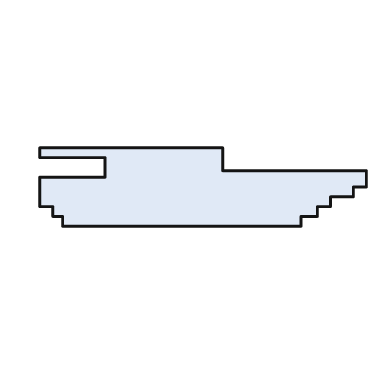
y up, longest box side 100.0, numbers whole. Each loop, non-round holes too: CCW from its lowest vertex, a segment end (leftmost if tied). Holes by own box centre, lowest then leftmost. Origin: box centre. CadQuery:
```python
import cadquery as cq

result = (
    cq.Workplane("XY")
    .moveTo(-43.0, -12.0)
    .lineTo(30.0, -12.0)
    .lineTo(30.0, -9.0)
    .lineTo(35.0, -9.0)
    .lineTo(35.0, -6.0)
    .lineTo(39.0, -6.0)
    .lineTo(39.0, -3.0)
    .lineTo(46.0, -3.0)
    .lineTo(46.0, 0.0)
    .lineTo(50.0, 0.0)
    .lineTo(50.0, 5.0)
    .lineTo(6.0, 5.0)
    .lineTo(6.0, 12.0)
    .lineTo(-50.0, 12.0)
    .lineTo(-50.0, 9.0)
    .lineTo(-30.0, 9.0)
    .lineTo(-30.0, 3.0)
    .lineTo(-50.0, 3.0)
    .lineTo(-50.0, -6.0)
    .lineTo(-46.0, -6.0)
    .lineTo(-46.0, -9.0)
    .lineTo(-43.0, -9.0)
    .close()
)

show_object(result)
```